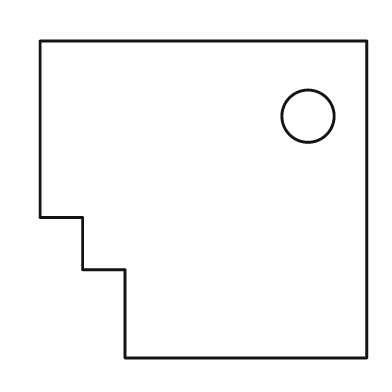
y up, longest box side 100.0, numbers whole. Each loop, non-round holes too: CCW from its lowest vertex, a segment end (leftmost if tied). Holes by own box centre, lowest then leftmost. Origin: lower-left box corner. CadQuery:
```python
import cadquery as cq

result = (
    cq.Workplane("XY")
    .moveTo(26.0, 0.0)
    .lineTo(100.0, 0.0)
    .lineTo(100.0, 97.0)
    .lineTo(0.0, 97.0)
    .lineTo(0.0, 43.0)
    .lineTo(13.0, 43.0)
    .lineTo(13.0, 27.0)
    .lineTo(26.0, 27.0)
    .close()
    .moveTo(82.0, 74.0)
    .circle(8.0)
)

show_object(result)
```